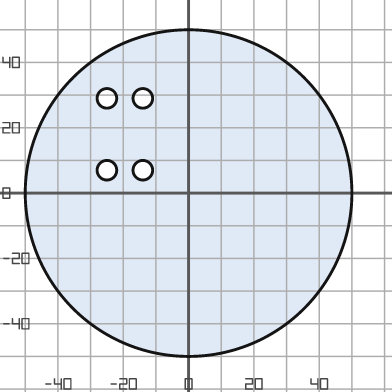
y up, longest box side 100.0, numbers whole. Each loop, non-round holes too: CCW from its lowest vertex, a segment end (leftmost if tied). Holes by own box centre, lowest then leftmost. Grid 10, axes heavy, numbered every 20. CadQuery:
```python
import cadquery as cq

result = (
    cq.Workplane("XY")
    .moveTo(0.0, 0.0)
    .circle(50.0)
    .moveTo(-25.0, 7.0)
    .circle(3.0)
    .moveTo(-14.0, 7.0)
    .circle(3.0)
    .moveTo(-25.0, 29.0)
    .circle(3.0)
    .moveTo(-14.0, 29.0)
    .circle(3.0)
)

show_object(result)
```